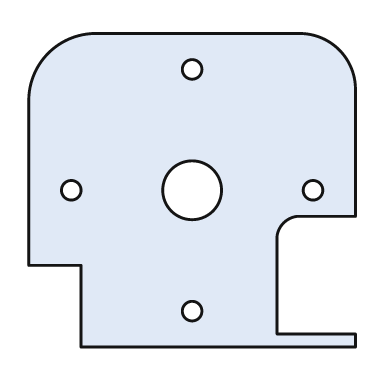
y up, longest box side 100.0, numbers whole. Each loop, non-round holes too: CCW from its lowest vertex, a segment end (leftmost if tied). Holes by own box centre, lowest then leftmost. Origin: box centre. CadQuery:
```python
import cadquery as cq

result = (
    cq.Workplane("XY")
    .moveTo(-34.0, -48.0)
    .lineTo(50.0, -48.0)
    .lineTo(50.0, -44.0)
    .lineTo(26.0, -44.0)
    .lineTo(26.0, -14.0)
    .threePointArc((28.0, -10.0), (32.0, -8.0))
    .lineTo(50.0, -8.0)
    .lineTo(50.0, 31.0)
    .threePointArc((45.0, 43.0), (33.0, 48.0))
    .lineTo(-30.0, 48.0)
    .threePointArc((-44.0, 42.0), (-50.0, 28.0))
    .lineTo(-50.0, -23.0)
    .lineTo(-34.0, -23.0)
    .close()
    .moveTo(0.0, -37.0)
    .circle(3.0)
    .moveTo(-37.0, 0.0)
    .circle(3.0)
    .moveTo(0.0, 0.0)
    .circle(9.0)
    .moveTo(37.0, 0.0)
    .circle(3.0)
    .moveTo(0.0, 37.0)
    .circle(3.0)
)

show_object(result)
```